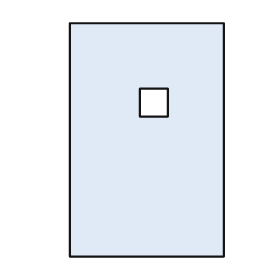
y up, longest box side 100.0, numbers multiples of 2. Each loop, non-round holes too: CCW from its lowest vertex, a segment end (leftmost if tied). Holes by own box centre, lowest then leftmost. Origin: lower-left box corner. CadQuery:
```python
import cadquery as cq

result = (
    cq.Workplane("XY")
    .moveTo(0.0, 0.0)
    .lineTo(66.0, 0.0)
    .lineTo(66.0, 100.0)
    .lineTo(0.0, 100.0)
    .close()
    .moveTo(30.0, 60.0)
    .lineTo(42.0, 60.0)
    .lineTo(42.0, 72.0)
    .lineTo(30.0, 72.0)
    .close()
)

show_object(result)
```